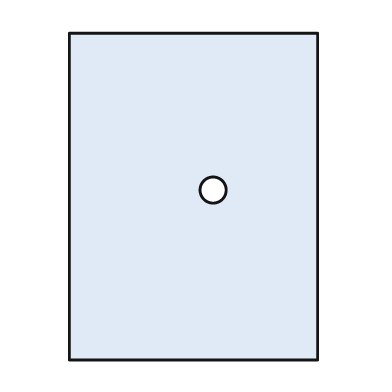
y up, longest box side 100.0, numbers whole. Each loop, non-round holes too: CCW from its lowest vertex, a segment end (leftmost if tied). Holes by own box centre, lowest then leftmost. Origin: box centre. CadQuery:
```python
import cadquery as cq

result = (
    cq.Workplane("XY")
    .moveTo(-38.0, -50.0)
    .lineTo(38.0, -50.0)
    .lineTo(38.0, 50.0)
    .lineTo(-38.0, 50.0)
    .close()
    .moveTo(6.0, 2.0)
    .circle(4.0)
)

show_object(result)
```